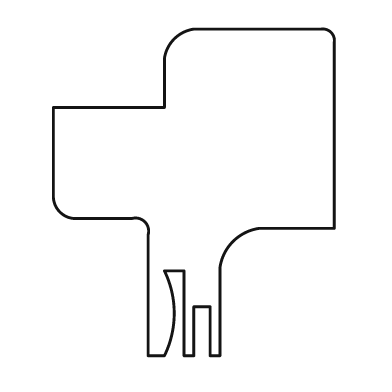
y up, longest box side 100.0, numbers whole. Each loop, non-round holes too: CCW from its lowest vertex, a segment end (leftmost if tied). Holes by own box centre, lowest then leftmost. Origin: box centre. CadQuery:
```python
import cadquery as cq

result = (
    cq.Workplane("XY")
    .moveTo(-14.0, -50.0)
    .lineTo(-9.0, -50.0)
    .threePointArc((-6.0, -37.0), (-9.0, -24.0))
    .lineTo(-3.0, -24.0)
    .lineTo(-3.0, -50.0)
    .lineTo(0.0, -50.0)
    .lineTo(0.0, -35.0)
    .lineTo(5.0, -35.0)
    .lineTo(5.0, -50.0)
    .lineTo(8.0, -50.0)
    .lineTo(8.0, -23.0)
    .threePointArc((12.0, -15.0), (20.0, -11.0))
    .lineTo(43.0, -11.0)
    .lineTo(43.0, 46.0)
    .threePointArc((42.0, 49.0), (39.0, 50.0))
    .lineTo(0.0, 50.0)
    .threePointArc((-6.0, 47.0), (-9.0, 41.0))
    .lineTo(-9.0, 26.0)
    .lineTo(-43.0, 26.0)
    .lineTo(-43.0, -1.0)
    .threePointArc((-41.0, -6.0), (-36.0, -8.0))
    .lineTo(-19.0, -8.0)
    .threePointArc((-15.0, -9.0), (-14.0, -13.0))
    .close()
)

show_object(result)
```